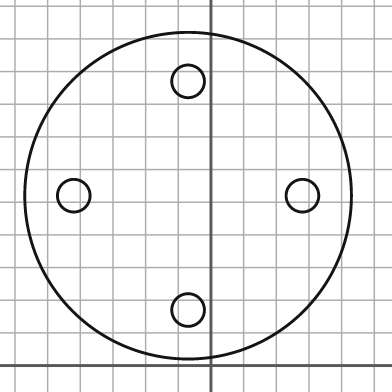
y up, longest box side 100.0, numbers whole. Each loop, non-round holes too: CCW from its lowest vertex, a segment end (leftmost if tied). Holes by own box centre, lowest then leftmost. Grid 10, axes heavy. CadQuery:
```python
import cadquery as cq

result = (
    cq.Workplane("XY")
    .moveTo(-7.0, 52.0)
    .circle(50.0)
    .moveTo(-7.0, 17.0)
    .circle(5.0)
    .moveTo(-42.0, 52.0)
    .circle(5.0)
    .moveTo(28.0, 52.0)
    .circle(5.0)
    .moveTo(-7.0, 87.0)
    .circle(5.0)
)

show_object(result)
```